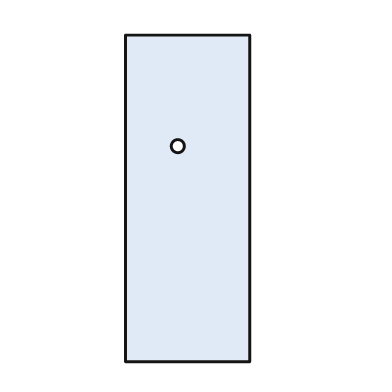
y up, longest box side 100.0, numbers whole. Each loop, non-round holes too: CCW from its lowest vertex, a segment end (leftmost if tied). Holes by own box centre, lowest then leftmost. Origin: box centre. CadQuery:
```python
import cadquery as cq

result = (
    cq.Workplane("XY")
    .moveTo(-19.0, -50.0)
    .lineTo(19.0, -50.0)
    .lineTo(19.0, 50.0)
    .lineTo(-19.0, 50.0)
    .close()
    .moveTo(-3.0, 16.0)
    .circle(2.0)
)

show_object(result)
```